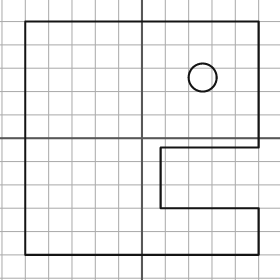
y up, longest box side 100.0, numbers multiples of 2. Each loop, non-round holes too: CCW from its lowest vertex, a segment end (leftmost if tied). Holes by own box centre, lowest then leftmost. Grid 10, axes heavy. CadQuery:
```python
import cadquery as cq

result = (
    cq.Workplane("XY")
    .moveTo(-50.0, -50.0)
    .lineTo(50.0, -50.0)
    .lineTo(50.0, -30.0)
    .lineTo(8.0, -30.0)
    .lineTo(8.0, -4.0)
    .lineTo(50.0, -4.0)
    .lineTo(50.0, 50.0)
    .lineTo(-50.0, 50.0)
    .close()
    .moveTo(26.0, 26.0)
    .circle(6.0)
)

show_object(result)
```